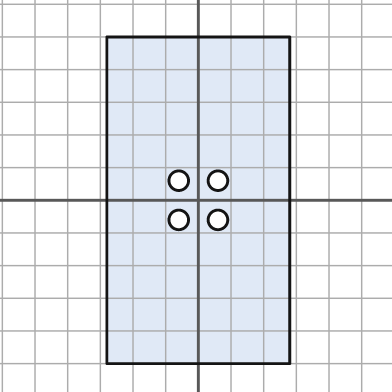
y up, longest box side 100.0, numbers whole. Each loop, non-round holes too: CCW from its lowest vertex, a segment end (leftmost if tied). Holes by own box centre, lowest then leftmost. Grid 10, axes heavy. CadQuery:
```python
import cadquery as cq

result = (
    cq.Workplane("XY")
    .moveTo(-28.0, -50.0)
    .lineTo(28.0, -50.0)
    .lineTo(28.0, 50.0)
    .lineTo(-28.0, 50.0)
    .close()
    .moveTo(-6.0, -6.0)
    .circle(3.0)
    .moveTo(6.0, -6.0)
    .circle(3.0)
    .moveTo(-6.0, 6.0)
    .circle(3.0)
    .moveTo(6.0, 6.0)
    .circle(3.0)
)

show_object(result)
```